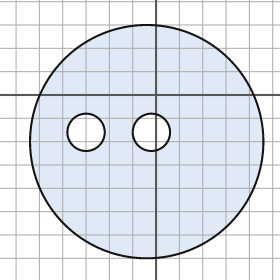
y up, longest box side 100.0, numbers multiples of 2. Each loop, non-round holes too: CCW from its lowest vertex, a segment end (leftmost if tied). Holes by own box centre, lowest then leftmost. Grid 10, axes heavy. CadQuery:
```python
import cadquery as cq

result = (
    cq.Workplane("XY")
    .moveTo(-4.0, -20.0)
    .circle(50.0)
    .moveTo(-30.0, -16.0)
    .circle(8.0)
    .moveTo(-2.0, -16.0)
    .circle(8.0)
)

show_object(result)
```